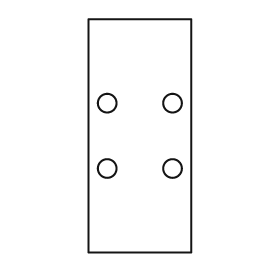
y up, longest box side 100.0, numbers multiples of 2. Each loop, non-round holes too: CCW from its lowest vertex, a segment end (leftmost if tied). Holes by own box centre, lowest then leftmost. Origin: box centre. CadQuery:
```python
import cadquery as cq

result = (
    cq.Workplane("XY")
    .moveTo(-22.0, -50.0)
    .lineTo(22.0, -50.0)
    .lineTo(22.0, 50.0)
    .lineTo(-22.0, 50.0)
    .close()
    .moveTo(-14.0, -14.0)
    .circle(4.0)
    .moveTo(14.0, -14.0)
    .circle(4.0)
    .moveTo(-14.0, 14.0)
    .circle(4.0)
    .moveTo(14.0, 14.0)
    .circle(4.0)
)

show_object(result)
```